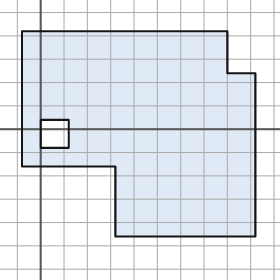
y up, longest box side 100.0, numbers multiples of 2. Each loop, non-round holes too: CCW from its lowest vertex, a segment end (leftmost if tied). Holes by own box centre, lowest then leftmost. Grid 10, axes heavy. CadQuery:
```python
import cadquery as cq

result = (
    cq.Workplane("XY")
    .moveTo(32.0, -46.0)
    .lineTo(92.0, -46.0)
    .lineTo(92.0, 24.0)
    .lineTo(80.0, 24.0)
    .lineTo(80.0, 42.0)
    .lineTo(-8.0, 42.0)
    .lineTo(-8.0, -16.0)
    .lineTo(32.0, -16.0)
    .close()
    .moveTo(0.0, -8.0)
    .lineTo(12.0, -8.0)
    .lineTo(12.0, 4.0)
    .lineTo(0.0, 4.0)
    .close()
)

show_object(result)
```